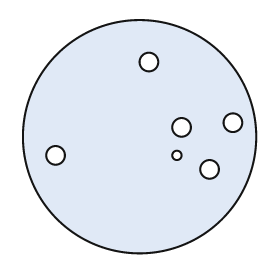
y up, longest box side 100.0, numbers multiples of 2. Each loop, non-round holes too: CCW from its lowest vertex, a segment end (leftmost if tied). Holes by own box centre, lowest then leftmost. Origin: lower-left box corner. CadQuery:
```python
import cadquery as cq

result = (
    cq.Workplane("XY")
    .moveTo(50.0, 50.0)
    .circle(50.0)
    .moveTo(80.0, 36.0)
    .circle(4.0)
    .moveTo(14.0, 42.0)
    .circle(4.0)
    .moveTo(66.0, 42.0)
    .circle(2.0)
    .moveTo(68.0, 54.0)
    .circle(4.0)
    .moveTo(90.0, 56.0)
    .circle(4.0)
    .moveTo(54.0, 82.0)
    .circle(4.0)
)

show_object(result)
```